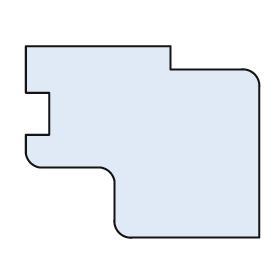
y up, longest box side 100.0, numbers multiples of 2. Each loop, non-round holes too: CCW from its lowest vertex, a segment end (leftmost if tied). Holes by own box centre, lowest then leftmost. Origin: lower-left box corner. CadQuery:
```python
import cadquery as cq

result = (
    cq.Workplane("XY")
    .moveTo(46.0, 0.0)
    .lineTo(100.0, 0.0)
    .lineTo(100.0, 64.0)
    .threePointArc((98.0, 70.0), (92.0, 72.0))
    .lineTo(62.0, 72.0)
    .lineTo(62.0, 82.0)
    .lineTo(0.0, 82.0)
    .lineTo(0.0, 62.0)
    .lineTo(10.0, 62.0)
    .lineTo(10.0, 44.0)
    .lineTo(0.0, 44.0)
    .lineTo(0.0, 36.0)
    .threePointArc((2.0, 32.0), (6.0, 30.0))
    .lineTo(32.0, 30.0)
    .threePointArc((36.0, 28.0), (38.0, 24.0))
    .lineTo(38.0, 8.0)
    .threePointArc((40.0, 2.0), (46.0, 0.0))
    .close()
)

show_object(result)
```